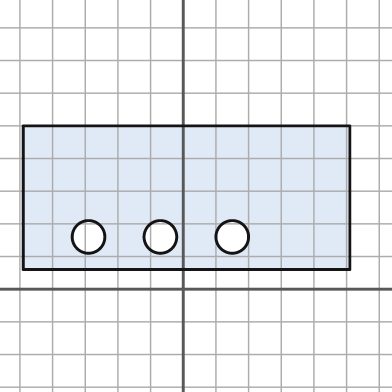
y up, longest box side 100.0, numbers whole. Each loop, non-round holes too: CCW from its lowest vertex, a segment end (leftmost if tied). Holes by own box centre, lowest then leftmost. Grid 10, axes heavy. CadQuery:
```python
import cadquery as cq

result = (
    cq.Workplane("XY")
    .moveTo(-49.0, 6.0)
    .lineTo(51.0, 6.0)
    .lineTo(51.0, 50.0)
    .lineTo(-49.0, 50.0)
    .close()
    .moveTo(-29.0, 16.0)
    .circle(5.0)
    .moveTo(-7.0, 16.0)
    .circle(5.0)
    .moveTo(15.0, 16.0)
    .circle(5.0)
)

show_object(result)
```